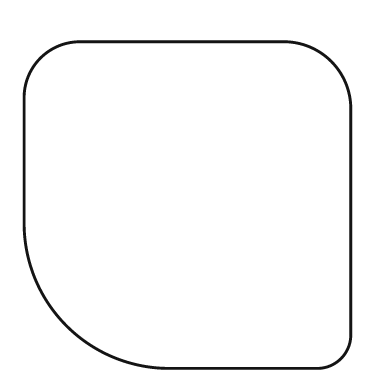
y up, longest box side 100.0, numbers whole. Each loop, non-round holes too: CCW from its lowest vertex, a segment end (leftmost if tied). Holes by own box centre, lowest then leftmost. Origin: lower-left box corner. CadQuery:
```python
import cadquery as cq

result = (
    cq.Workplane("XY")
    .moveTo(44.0, 0.0)
    .lineTo(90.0, 0.0)
    .threePointArc((97.0, 3.0), (100.0, 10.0))
    .lineTo(100.0, 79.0)
    .threePointArc((94.0, 94.0), (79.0, 100.0))
    .lineTo(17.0, 100.0)
    .threePointArc((5.0, 95.0), (0.0, 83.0))
    .lineTo(0.0, 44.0)
    .threePointArc((13.0, 13.0), (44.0, 0.0))
    .close()
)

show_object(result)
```